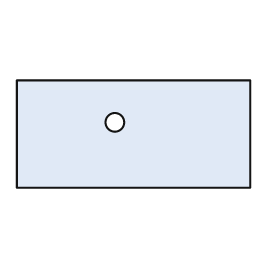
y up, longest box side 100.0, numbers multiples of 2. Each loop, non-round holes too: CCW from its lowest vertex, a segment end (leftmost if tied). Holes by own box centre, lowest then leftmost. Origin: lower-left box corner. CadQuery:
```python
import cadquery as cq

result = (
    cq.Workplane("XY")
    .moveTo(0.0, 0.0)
    .lineTo(100.0, 0.0)
    .lineTo(100.0, 46.0)
    .lineTo(0.0, 46.0)
    .close()
    .moveTo(42.0, 28.0)
    .circle(4.0)
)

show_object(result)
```